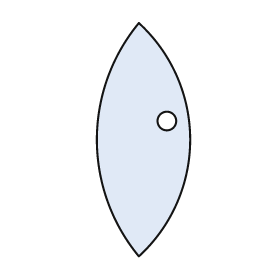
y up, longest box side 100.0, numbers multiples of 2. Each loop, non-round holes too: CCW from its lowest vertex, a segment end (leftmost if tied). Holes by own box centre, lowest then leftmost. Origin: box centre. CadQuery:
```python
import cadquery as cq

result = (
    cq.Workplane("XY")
    .moveTo(-2.0, -50.0)
    .threePointArc((20.0, 0.0), (-2.0, 50.0))
    .threePointArc((-20.0, 0.0), (-2.0, -50.0))
    .close()
    .moveTo(10.0, 8.0)
    .circle(4.0)
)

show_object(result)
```